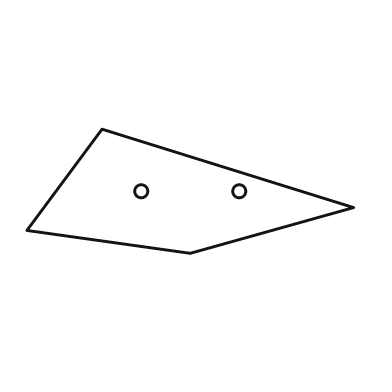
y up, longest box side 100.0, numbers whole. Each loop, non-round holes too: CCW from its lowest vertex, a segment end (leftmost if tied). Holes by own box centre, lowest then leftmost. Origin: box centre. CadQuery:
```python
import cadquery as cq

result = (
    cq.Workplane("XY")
    .moveTo(0.0, -19.0)
    .lineTo(50.0, -5.0)
    .lineTo(-27.0, 19.0)
    .lineTo(-50.0, -12.0)
    .close()
    .moveTo(-15.0, 0.0)
    .circle(2.0)
    .moveTo(15.0, 0.0)
    .circle(2.0)
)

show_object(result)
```